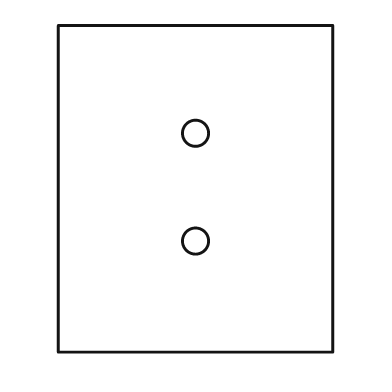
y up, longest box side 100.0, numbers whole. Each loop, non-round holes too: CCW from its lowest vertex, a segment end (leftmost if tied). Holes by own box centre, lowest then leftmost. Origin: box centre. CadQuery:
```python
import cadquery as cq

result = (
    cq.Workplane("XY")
    .moveTo(-42.0, -50.0)
    .lineTo(42.0, -50.0)
    .lineTo(42.0, 50.0)
    .lineTo(-42.0, 50.0)
    .close()
    .moveTo(0.0, -16.0)
    .circle(4.0)
    .moveTo(0.0, 17.0)
    .circle(4.0)
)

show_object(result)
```